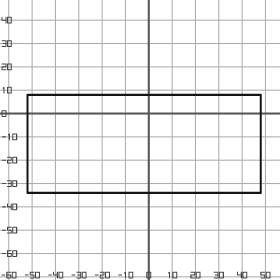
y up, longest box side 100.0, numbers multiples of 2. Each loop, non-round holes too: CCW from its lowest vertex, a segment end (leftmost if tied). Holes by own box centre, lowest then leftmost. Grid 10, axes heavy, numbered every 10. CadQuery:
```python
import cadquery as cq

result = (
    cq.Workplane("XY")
    .moveTo(-52.0, -34.0)
    .lineTo(48.0, -34.0)
    .lineTo(48.0, 8.0)
    .lineTo(-52.0, 8.0)
    .close()
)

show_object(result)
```